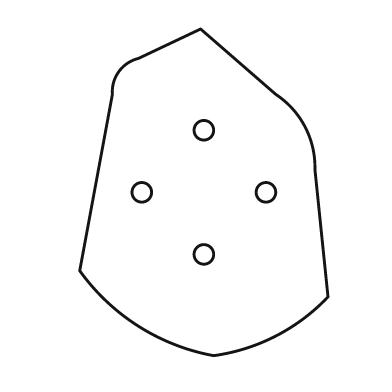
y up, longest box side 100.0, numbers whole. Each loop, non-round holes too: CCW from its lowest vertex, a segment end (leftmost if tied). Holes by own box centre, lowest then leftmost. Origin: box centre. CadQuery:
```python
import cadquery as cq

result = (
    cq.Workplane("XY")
    .moveTo(3.0, -50.0)
    .threePointArc((22.0, -44.0), (38.0, -32.0))
    .lineTo(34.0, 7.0)
    .threePointArc((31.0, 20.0), (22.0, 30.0))
    .lineTo(-1.0, 50.0)
    .lineTo(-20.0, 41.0)
    .threePointArc((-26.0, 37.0), (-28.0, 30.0))
    .lineTo(-38.0, -24.0)
    .threePointArc((-20.0, -41.0), (3.0, -50.0))
    .close()
    .moveTo(0.0, -19.0)
    .circle(3.0)
    .moveTo(-19.0, 0.0)
    .circle(3.0)
    .moveTo(19.0, 0.0)
    .circle(3.0)
    .moveTo(0.0, 19.0)
    .circle(3.0)
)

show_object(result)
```